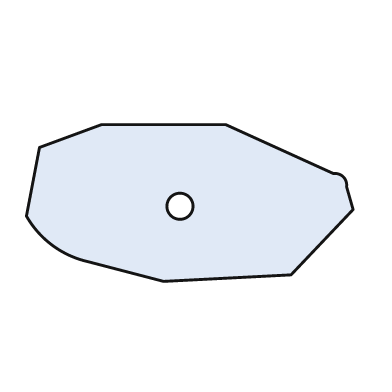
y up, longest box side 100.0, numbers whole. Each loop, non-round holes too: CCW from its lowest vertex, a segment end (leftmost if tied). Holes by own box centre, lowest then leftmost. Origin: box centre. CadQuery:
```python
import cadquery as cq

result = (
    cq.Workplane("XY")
    .moveTo(-8.0, -24.0)
    .lineTo(31.0, -22.0)
    .lineTo(50.0, -2.0)
    .lineTo(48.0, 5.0)
    .threePointArc((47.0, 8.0), (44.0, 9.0))
    .lineTo(11.0, 24.0)
    .lineTo(-27.0, 24.0)
    .lineTo(-46.0, 17.0)
    .lineTo(-50.0, -4.0)
    .threePointArc((-42.0, -13.0), (-31.0, -18.0))
    .close()
    .moveTo(-3.0, -1.0)
    .circle(4.0)
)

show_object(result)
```